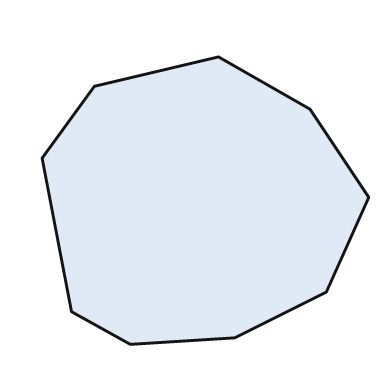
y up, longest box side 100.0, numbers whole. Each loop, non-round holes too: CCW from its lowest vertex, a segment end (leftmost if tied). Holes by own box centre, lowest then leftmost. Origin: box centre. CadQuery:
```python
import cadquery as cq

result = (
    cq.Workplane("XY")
    .moveTo(-23.0, -44.0)
    .lineTo(9.0, -42.0)
    .lineTo(37.0, -28.0)
    .lineTo(50.0, 1.0)
    .lineTo(32.0, 28.0)
    .lineTo(4.0, 44.0)
    .lineTo(-34.0, 35.0)
    .lineTo(-50.0, 13.0)
    .lineTo(-41.0, -34.0)
    .close()
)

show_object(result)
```